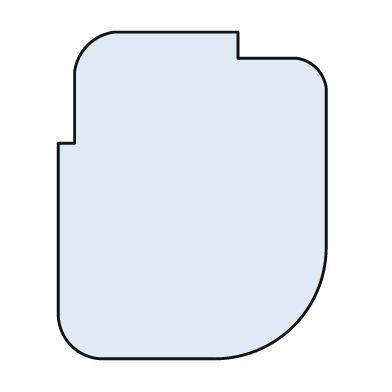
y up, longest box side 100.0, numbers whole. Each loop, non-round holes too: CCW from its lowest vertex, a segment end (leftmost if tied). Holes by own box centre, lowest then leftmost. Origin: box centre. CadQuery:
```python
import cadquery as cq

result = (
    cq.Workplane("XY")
    .moveTo(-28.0, -50.0)
    .lineTo(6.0, -50.0)
    .threePointArc((31.0, -40.0), (41.0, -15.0))
    .lineTo(41.0, 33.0)
    .threePointArc((38.0, 39.0), (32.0, 42.0))
    .lineTo(14.0, 42.0)
    .lineTo(14.0, 50.0)
    .lineTo(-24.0, 50.0)
    .threePointArc((-32.0, 46.0), (-36.0, 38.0))
    .lineTo(-36.0, 16.0)
    .lineTo(-41.0, 16.0)
    .lineTo(-41.0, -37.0)
    .threePointArc((-37.0, -46.0), (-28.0, -50.0))
    .close()
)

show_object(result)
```